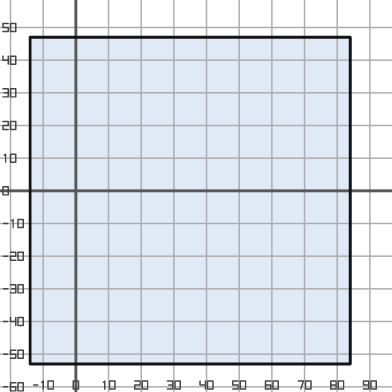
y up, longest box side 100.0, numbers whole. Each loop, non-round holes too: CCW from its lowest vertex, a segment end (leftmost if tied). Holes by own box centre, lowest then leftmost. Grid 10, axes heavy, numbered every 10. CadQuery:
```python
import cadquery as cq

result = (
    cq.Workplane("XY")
    .moveTo(-14.0, -53.0)
    .lineTo(84.0, -53.0)
    .lineTo(84.0, 47.0)
    .lineTo(-14.0, 47.0)
    .close()
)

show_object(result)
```